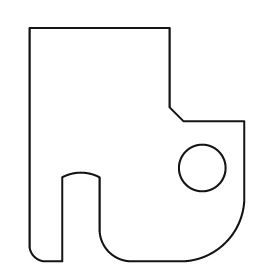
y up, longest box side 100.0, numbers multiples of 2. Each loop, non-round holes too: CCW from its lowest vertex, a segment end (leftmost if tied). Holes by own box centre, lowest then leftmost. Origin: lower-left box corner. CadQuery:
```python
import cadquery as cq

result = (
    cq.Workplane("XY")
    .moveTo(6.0, 0.0)
    .lineTo(14.0, 0.0)
    .lineTo(14.0, 36.0)
    .threePointArc((22.0, 38.0), (30.0, 36.0))
    .lineTo(30.0, 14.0)
    .threePointArc((34.0, 4.0), (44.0, 0.0))
    .lineTo(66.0, 0.0)
    .threePointArc((84.0, 8.0), (92.0, 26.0))
    .lineTo(92.0, 60.0)
    .lineTo(66.0, 60.0)
    .lineTo(60.0, 66.0)
    .lineTo(60.0, 100.0)
    .lineTo(0.0, 100.0)
    .lineTo(0.0, 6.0)
    .threePointArc((2.0, 2.0), (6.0, 0.0))
    .close()
    .moveTo(74.0, 40.0)
    .circle(10.0)
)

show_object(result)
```